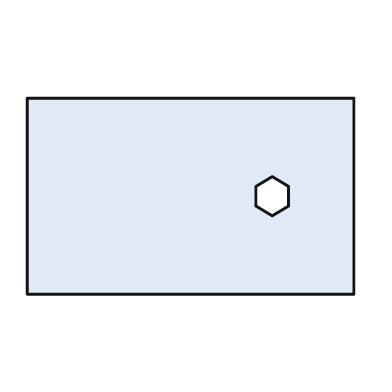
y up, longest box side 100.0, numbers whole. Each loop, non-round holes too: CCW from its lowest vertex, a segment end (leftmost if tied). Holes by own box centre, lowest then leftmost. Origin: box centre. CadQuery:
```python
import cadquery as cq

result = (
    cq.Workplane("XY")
    .moveTo(-50.0, -30.0)
    .lineTo(50.0, -30.0)
    .lineTo(50.0, 30.0)
    .lineTo(-50.0, 30.0)
    .close()
    .moveTo(25.0, -6.0)
    .lineTo(30.0, -3.0)
    .lineTo(30.0, 3.0)
    .lineTo(25.0, 6.0)
    .lineTo(20.0, 3.0)
    .lineTo(20.0, -3.0)
    .close()
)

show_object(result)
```